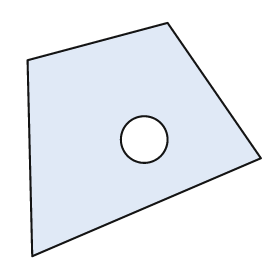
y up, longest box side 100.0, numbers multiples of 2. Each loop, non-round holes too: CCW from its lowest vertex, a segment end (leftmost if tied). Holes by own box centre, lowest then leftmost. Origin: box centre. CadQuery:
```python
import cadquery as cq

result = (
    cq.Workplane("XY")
    .moveTo(-48.0, -50.0)
    .lineTo(50.0, -8.0)
    .lineTo(10.0, 50.0)
    .lineTo(-50.0, 34.0)
    .close()
    .moveTo(0.0, 0.0)
    .circle(10.0)
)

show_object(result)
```